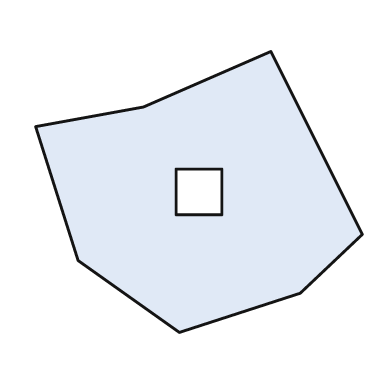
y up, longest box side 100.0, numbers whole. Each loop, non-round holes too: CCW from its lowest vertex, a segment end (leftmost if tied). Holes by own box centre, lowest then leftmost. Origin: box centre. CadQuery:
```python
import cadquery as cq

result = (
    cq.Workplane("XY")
    .moveTo(-6.0, -43.0)
    .lineTo(31.0, -31.0)
    .lineTo(50.0, -13.0)
    .lineTo(22.0, 43.0)
    .lineTo(-17.0, 26.0)
    .lineTo(-50.0, 20.0)
    .lineTo(-37.0, -21.0)
    .close()
    .moveTo(-7.0, -7.0)
    .lineTo(7.0, -7.0)
    .lineTo(7.0, 7.0)
    .lineTo(-7.0, 7.0)
    .close()
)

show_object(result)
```